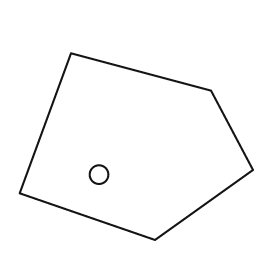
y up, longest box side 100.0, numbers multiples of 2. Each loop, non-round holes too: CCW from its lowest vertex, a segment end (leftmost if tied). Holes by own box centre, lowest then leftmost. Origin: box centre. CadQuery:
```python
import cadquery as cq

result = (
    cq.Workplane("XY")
    .moveTo(8.0, -40.0)
    .lineTo(50.0, -10.0)
    .lineTo(32.0, 24.0)
    .lineTo(-28.0, 40.0)
    .lineTo(-50.0, -20.0)
    .close()
    .moveTo(-16.0, -12.0)
    .circle(4.0)
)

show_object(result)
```